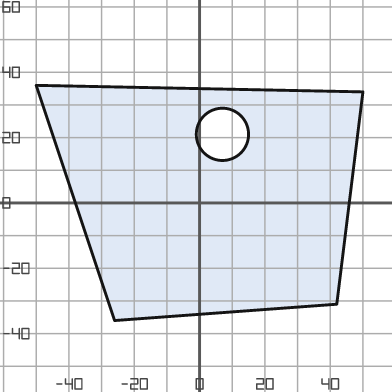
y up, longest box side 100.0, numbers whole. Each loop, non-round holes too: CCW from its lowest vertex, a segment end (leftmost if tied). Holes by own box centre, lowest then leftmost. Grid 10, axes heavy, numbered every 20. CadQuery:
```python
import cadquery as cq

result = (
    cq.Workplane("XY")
    .moveTo(-26.0, -36.0)
    .lineTo(42.0, -31.0)
    .lineTo(50.0, 34.0)
    .lineTo(-50.0, 36.0)
    .close()
    .moveTo(7.0, 21.0)
    .circle(8.0)
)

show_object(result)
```